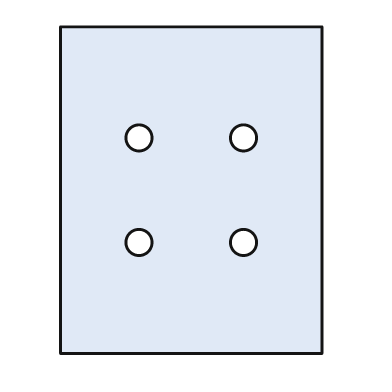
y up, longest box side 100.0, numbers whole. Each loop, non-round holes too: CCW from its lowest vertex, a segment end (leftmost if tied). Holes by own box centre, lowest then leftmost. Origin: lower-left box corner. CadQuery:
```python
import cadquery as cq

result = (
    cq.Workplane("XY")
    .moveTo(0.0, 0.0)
    .lineTo(80.0, 0.0)
    .lineTo(80.0, 100.0)
    .lineTo(0.0, 100.0)
    .close()
    .moveTo(24.0, 34.0)
    .circle(4.0)
    .moveTo(56.0, 34.0)
    .circle(4.0)
    .moveTo(24.0, 66.0)
    .circle(4.0)
    .moveTo(56.0, 66.0)
    .circle(4.0)
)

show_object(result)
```